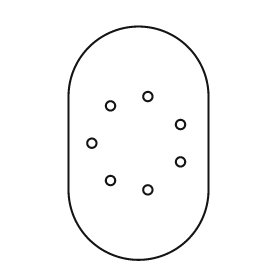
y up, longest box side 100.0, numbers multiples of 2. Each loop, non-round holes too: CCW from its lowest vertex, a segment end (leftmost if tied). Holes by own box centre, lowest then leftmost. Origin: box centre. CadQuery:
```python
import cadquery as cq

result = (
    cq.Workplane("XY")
    .moveTo(-30.0, -20.0)
    .threePointArc((0.0, -50.0), (30.0, -20.0))
    .lineTo(30.0, 20.0)
    .threePointArc((0.0, 50.0), (-30.0, 20.0))
    .close()
    .moveTo(4.0, -20.0)
    .circle(2.0)
    .moveTo(-12.0, -16.0)
    .circle(2.0)
    .moveTo(18.0, -8.0)
    .circle(2.0)
    .moveTo(-20.0, 0.0)
    .circle(2.0)
    .moveTo(18.0, 8.0)
    .circle(2.0)
    .moveTo(-12.0, 16.0)
    .circle(2.0)
    .moveTo(4.0, 20.0)
    .circle(2.0)
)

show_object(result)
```